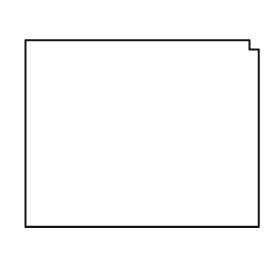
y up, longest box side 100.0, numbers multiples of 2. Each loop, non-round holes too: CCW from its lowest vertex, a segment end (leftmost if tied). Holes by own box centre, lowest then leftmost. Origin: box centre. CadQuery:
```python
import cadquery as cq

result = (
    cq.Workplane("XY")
    .moveTo(-50.0, -40.0)
    .lineTo(50.0, -40.0)
    .lineTo(50.0, 36.0)
    .lineTo(46.0, 36.0)
    .lineTo(46.0, 40.0)
    .lineTo(-50.0, 40.0)
    .close()
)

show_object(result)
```